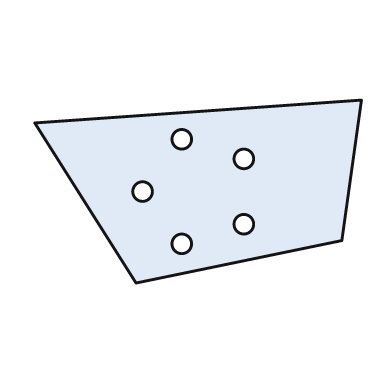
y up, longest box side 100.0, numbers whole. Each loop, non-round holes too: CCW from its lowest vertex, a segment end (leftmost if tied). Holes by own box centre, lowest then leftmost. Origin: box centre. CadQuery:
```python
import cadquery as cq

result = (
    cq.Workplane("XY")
    .moveTo(-19.0, -28.0)
    .lineTo(44.0, -15.0)
    .lineTo(50.0, 28.0)
    .lineTo(-50.0, 21.0)
    .close()
    .moveTo(-5.0, -16.0)
    .circle(3.0)
    .moveTo(14.0, -10.0)
    .circle(3.0)
    .moveTo(-17.0, 0.0)
    .circle(3.0)
    .moveTo(14.0, 10.0)
    .circle(3.0)
    .moveTo(-5.0, 16.0)
    .circle(3.0)
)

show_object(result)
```